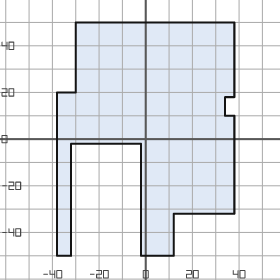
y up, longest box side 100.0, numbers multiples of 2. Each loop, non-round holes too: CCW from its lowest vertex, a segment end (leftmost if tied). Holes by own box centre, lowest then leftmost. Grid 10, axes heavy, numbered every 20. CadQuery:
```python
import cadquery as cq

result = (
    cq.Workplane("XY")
    .moveTo(-38.0, -50.0)
    .lineTo(-32.0, -50.0)
    .lineTo(-32.0, -2.0)
    .lineTo(-2.0, -2.0)
    .lineTo(-2.0, -50.0)
    .lineTo(12.0, -50.0)
    .lineTo(12.0, -32.0)
    .lineTo(38.0, -32.0)
    .lineTo(38.0, 10.0)
    .lineTo(34.0, 10.0)
    .lineTo(34.0, 18.0)
    .lineTo(38.0, 18.0)
    .lineTo(38.0, 50.0)
    .lineTo(-30.0, 50.0)
    .lineTo(-30.0, 20.0)
    .lineTo(-38.0, 20.0)
    .close()
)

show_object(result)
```